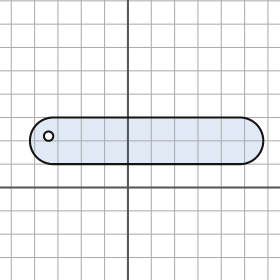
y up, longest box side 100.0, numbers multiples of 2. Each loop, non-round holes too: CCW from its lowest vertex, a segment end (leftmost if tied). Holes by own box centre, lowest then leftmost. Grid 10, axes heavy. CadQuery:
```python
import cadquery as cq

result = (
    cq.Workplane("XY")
    .moveTo(-32.0, 10.0)
    .lineTo(48.0, 10.0)
    .threePointArc((58.0, 20.0), (48.0, 30.0))
    .lineTo(-32.0, 30.0)
    .threePointArc((-42.0, 20.0), (-32.0, 10.0))
    .close()
    .moveTo(-34.0, 22.0)
    .circle(2.0)
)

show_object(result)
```